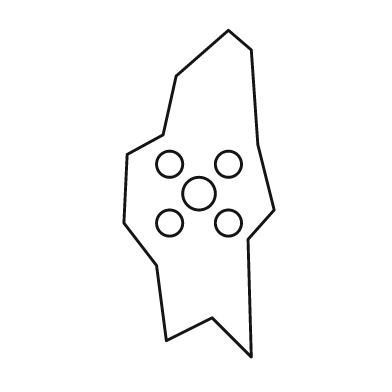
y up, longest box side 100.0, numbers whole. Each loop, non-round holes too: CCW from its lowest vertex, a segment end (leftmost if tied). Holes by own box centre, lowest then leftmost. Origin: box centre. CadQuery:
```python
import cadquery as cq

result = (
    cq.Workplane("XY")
    .moveTo(16.0, -50.0)
    .lineTo(15.0, -14.0)
    .lineTo(23.0, -5.0)
    .lineTo(18.0, 15.0)
    .lineTo(16.0, 44.0)
    .lineTo(9.0, 50.0)
    .lineTo(-7.0, 36.0)
    .lineTo(-11.0, 18.0)
    .lineTo(-22.0, 12.0)
    .lineTo(-23.0, -9.0)
    .lineTo(-13.0, -22.0)
    .lineTo(-10.0, -45.0)
    .lineTo(4.0, -38.0)
    .close()
    .moveTo(-9.0, -9.0)
    .circle(4.0)
    .moveTo(9.0, -9.0)
    .circle(4.0)
    .moveTo(0.0, 0.0)
    .circle(5.0)
    .moveTo(-9.0, 9.0)
    .circle(4.0)
    .moveTo(9.0, 9.0)
    .circle(4.0)
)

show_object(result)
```